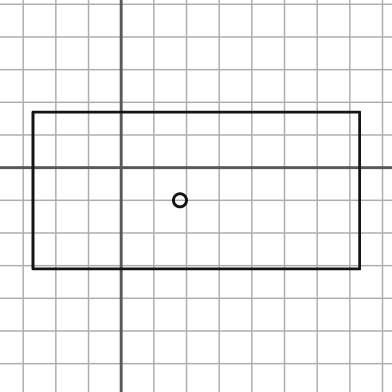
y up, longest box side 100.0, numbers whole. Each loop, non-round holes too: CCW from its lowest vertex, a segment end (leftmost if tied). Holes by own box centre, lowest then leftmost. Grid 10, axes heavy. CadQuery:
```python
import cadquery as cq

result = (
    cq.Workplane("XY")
    .moveTo(-27.0, -31.0)
    .lineTo(73.0, -31.0)
    .lineTo(73.0, 17.0)
    .lineTo(-27.0, 17.0)
    .close()
    .moveTo(18.0, -10.0)
    .circle(2.0)
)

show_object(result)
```